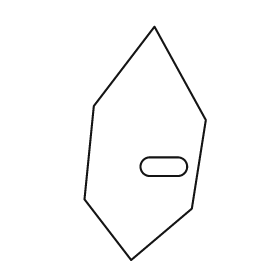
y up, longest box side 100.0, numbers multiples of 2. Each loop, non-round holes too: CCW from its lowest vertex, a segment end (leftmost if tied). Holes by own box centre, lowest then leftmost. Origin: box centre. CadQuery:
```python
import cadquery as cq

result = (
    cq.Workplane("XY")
    .moveTo(-6.0, -50.0)
    .lineTo(20.0, -28.0)
    .lineTo(26.0, 10.0)
    .lineTo(4.0, 50.0)
    .lineTo(-22.0, 16.0)
    .lineTo(-26.0, -24.0)
    .close()
    .moveTo(2.0, -14.0)
    .lineTo(14.0, -14.0)
    .threePointArc((18.0, -10.0), (14.0, -6.0))
    .lineTo(2.0, -6.0)
    .threePointArc((-2.0, -10.0), (2.0, -14.0))
    .close()
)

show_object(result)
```